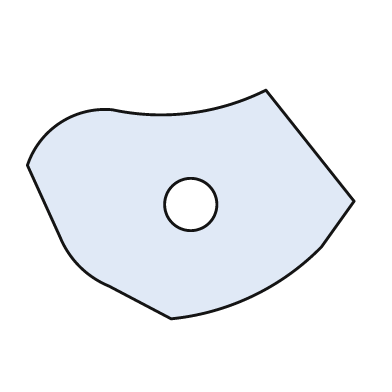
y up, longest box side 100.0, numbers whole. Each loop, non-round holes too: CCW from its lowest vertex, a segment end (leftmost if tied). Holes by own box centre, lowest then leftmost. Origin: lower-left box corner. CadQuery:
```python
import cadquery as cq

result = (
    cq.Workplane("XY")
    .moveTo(44.0, 0.0)
    .threePointArc((69.0, 7.0), (90.0, 22.0))
    .lineTo(100.0, 36.0)
    .lineTo(73.0, 70.0)
    .threePointArc((50.0, 63.0), (26.0, 64.0))
    .threePointArc((10.0, 60.0), (0.0, 47.0))
    .lineTo(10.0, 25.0)
    .threePointArc((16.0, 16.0), (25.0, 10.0))
    .close()
    .moveTo(50.0, 35.0)
    .circle(8.0)
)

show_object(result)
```